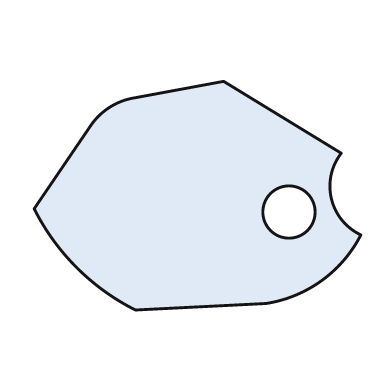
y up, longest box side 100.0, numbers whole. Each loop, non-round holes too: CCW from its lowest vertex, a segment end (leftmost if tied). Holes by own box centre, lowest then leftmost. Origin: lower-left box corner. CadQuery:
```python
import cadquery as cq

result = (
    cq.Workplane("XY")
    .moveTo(31.0, 0.0)
    .lineTo(71.0, 2.0)
    .threePointArc((88.0, 9.0), (100.0, 23.0))
    .threePointArc((91.0, 34.0), (94.0, 48.0))
    .lineTo(58.0, 70.0)
    .lineTo(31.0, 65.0)
    .threePointArc((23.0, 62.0), (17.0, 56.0))
    .lineTo(0.0, 31.0)
    .threePointArc((13.0, 13.0), (31.0, 0.0))
    .close()
    .moveTo(78.0, 30.0)
    .circle(8.0)
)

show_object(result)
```